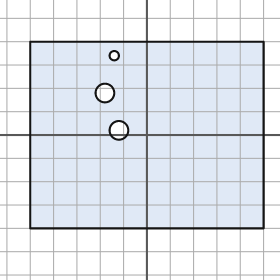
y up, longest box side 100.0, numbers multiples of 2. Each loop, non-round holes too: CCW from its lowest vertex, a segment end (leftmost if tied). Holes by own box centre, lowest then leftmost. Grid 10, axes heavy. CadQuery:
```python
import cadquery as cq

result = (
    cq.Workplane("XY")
    .moveTo(-50.0, -40.0)
    .lineTo(50.0, -40.0)
    .lineTo(50.0, 40.0)
    .lineTo(-50.0, 40.0)
    .close()
    .moveTo(-12.0, 2.0)
    .circle(4.0)
    .moveTo(-18.0, 18.0)
    .circle(4.0)
    .moveTo(-14.0, 34.0)
    .circle(2.0)
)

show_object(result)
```